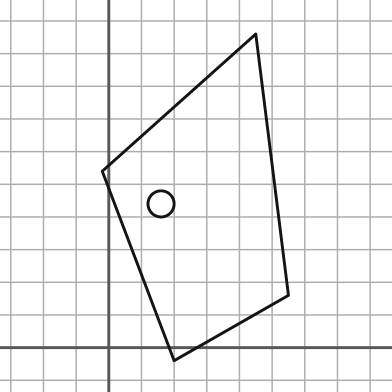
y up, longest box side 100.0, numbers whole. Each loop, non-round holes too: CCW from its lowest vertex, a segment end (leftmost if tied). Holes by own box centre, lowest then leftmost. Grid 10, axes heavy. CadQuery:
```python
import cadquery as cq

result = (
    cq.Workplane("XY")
    .moveTo(20.0, -4.0)
    .lineTo(55.0, 16.0)
    .lineTo(45.0, 96.0)
    .lineTo(-2.0, 54.0)
    .close()
    .moveTo(16.0, 44.0)
    .circle(4.0)
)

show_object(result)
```